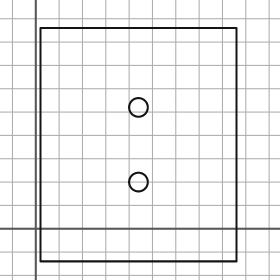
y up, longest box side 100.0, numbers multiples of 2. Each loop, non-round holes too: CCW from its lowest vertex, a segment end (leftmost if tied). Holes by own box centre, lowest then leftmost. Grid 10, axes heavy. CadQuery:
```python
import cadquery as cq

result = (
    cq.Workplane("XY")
    .moveTo(2.0, -14.0)
    .lineTo(86.0, -14.0)
    .lineTo(86.0, 86.0)
    .lineTo(2.0, 86.0)
    .close()
    .moveTo(44.0, 20.0)
    .circle(4.0)
    .moveTo(44.0, 52.0)
    .circle(4.0)
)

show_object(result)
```